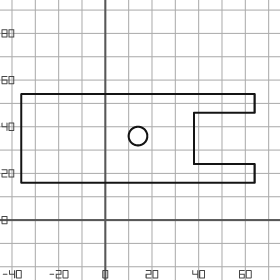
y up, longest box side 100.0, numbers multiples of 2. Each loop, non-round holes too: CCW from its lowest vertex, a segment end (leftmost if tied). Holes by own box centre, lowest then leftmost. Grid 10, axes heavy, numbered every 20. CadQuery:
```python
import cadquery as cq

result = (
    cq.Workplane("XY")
    .moveTo(-36.0, 16.0)
    .lineTo(64.0, 16.0)
    .lineTo(64.0, 24.0)
    .lineTo(38.0, 24.0)
    .lineTo(38.0, 46.0)
    .lineTo(64.0, 46.0)
    .lineTo(64.0, 54.0)
    .lineTo(-36.0, 54.0)
    .close()
    .moveTo(14.0, 36.0)
    .circle(4.0)
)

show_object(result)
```